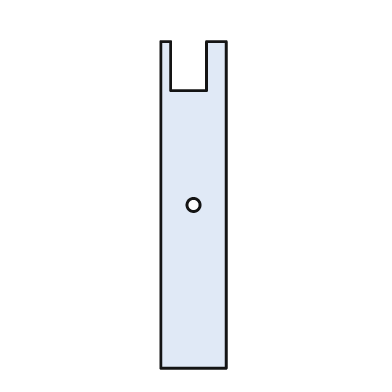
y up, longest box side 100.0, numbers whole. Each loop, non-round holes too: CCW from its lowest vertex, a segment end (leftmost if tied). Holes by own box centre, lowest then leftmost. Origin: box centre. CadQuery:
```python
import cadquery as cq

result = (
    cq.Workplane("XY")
    .moveTo(-10.0, -50.0)
    .lineTo(10.0, -50.0)
    .lineTo(10.0, 50.0)
    .lineTo(4.0, 50.0)
    .lineTo(4.0, 35.0)
    .lineTo(-7.0, 35.0)
    .lineTo(-7.0, 50.0)
    .lineTo(-10.0, 50.0)
    .close()
    .moveTo(0.0, 0.0)
    .circle(2.0)
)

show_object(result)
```